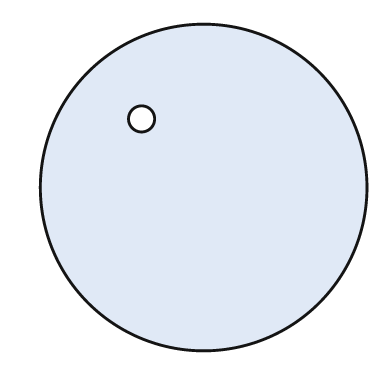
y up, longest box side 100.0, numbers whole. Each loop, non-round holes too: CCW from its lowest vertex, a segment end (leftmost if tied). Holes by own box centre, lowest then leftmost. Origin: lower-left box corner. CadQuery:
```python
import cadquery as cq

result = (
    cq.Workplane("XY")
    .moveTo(50.0, 50.0)
    .circle(50.0)
    .moveTo(31.0, 71.0)
    .circle(4.0)
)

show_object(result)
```